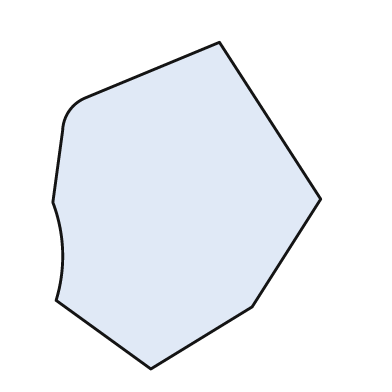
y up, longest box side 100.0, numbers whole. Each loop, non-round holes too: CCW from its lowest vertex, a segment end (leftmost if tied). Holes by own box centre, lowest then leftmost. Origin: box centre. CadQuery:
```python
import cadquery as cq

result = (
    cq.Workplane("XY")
    .moveTo(-11.0, -50.0)
    .lineTo(20.0, -31.0)
    .lineTo(41.0, 2.0)
    .lineTo(10.0, 50.0)
    .lineTo(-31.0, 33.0)
    .threePointArc((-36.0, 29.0), (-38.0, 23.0))
    .lineTo(-41.0, 1.0)
    .threePointArc((-38.0, -14.0), (-40.0, -29.0))
    .close()
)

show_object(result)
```